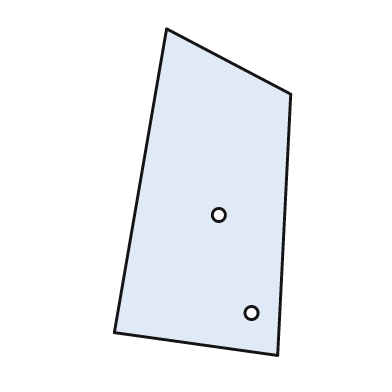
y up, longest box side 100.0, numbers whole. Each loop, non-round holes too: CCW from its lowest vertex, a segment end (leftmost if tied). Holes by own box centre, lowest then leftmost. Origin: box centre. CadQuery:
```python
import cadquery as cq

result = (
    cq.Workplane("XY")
    .moveTo(23.0, -50.0)
    .lineTo(27.0, 30.0)
    .lineTo(-11.0, 50.0)
    .lineTo(-27.0, -43.0)
    .close()
    .moveTo(15.0, -37.0)
    .circle(2.0)
    .moveTo(5.0, -7.0)
    .circle(2.0)
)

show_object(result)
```